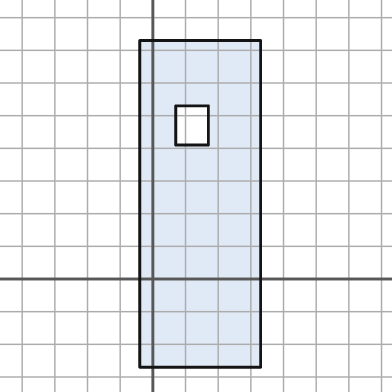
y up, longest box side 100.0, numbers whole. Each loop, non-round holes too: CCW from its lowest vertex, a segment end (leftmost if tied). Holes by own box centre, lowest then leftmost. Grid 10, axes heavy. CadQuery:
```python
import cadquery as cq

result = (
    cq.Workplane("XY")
    .moveTo(-4.0, -27.0)
    .lineTo(33.0, -27.0)
    .lineTo(33.0, 73.0)
    .lineTo(-4.0, 73.0)
    .close()
    .moveTo(7.0, 41.0)
    .lineTo(17.0, 41.0)
    .lineTo(17.0, 53.0)
    .lineTo(7.0, 53.0)
    .close()
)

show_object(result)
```